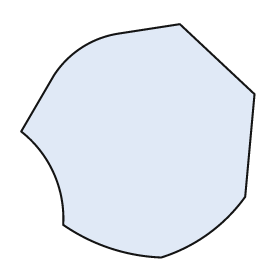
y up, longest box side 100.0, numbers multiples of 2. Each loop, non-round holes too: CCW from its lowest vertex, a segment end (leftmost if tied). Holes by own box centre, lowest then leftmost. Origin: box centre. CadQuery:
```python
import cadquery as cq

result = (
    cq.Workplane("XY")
    .moveTo(10.0, -50.0)
    .threePointArc((30.0, -40.0), (46.0, -24.0))
    .lineTo(50.0, 20.0)
    .lineTo(18.0, 50.0)
    .lineTo(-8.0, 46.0)
    .threePointArc((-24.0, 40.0), (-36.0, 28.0))
    .lineTo(-50.0, 4.0)
    .threePointArc((-36.0, -14.0), (-32.0, -36.0))
    .threePointArc((-12.0, -46.0), (10.0, -50.0))
    .close()
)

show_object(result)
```